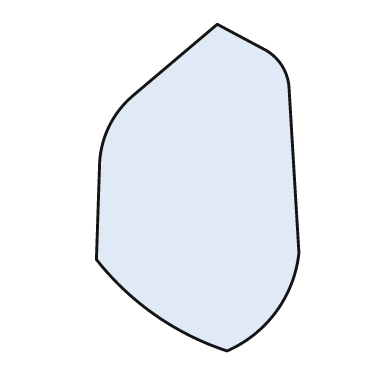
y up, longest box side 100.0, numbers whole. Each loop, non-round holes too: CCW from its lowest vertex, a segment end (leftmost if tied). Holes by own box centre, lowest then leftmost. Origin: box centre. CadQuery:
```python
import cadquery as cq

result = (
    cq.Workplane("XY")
    .moveTo(9.0, -50.0)
    .threePointArc((24.0, -38.0), (31.0, -20.0))
    .lineTo(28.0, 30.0)
    .threePointArc((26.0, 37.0), (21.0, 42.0))
    .lineTo(6.0, 50.0)
    .lineTo(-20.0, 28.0)
    .threePointArc((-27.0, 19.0), (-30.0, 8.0))
    .lineTo(-31.0, -22.0)
    .threePointArc((-13.0, -39.0), (9.0, -50.0))
    .close()
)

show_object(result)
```